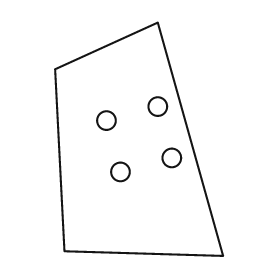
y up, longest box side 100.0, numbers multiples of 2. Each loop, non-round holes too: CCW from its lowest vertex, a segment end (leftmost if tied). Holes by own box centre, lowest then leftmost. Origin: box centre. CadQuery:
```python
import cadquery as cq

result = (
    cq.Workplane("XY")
    .moveTo(36.0, -50.0)
    .lineTo(8.0, 50.0)
    .lineTo(-36.0, 30.0)
    .lineTo(-32.0, -48.0)
    .close()
    .moveTo(-8.0, -14.0)
    .circle(4.0)
    .moveTo(14.0, -8.0)
    .circle(4.0)
    .moveTo(-14.0, 8.0)
    .circle(4.0)
    .moveTo(8.0, 14.0)
    .circle(4.0)
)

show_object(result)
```